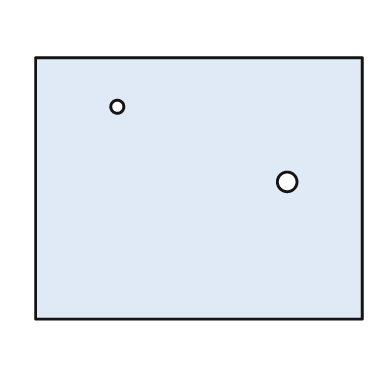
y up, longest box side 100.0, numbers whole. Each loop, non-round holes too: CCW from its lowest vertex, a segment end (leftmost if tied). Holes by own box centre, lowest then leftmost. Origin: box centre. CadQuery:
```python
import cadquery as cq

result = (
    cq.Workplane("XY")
    .moveTo(-50.0, -40.0)
    .lineTo(50.0, -40.0)
    .lineTo(50.0, 40.0)
    .lineTo(-50.0, 40.0)
    .close()
    .moveTo(27.0, 2.0)
    .circle(3.0)
    .moveTo(-25.0, 25.0)
    .circle(2.0)
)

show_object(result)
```